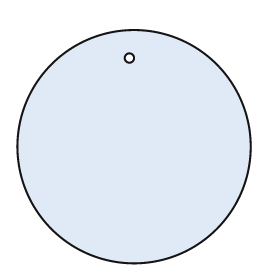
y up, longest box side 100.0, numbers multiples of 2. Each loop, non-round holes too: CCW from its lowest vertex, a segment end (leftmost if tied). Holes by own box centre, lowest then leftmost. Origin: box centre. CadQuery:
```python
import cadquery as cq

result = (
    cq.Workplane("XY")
    .moveTo(0.0, 0.0)
    .circle(50.0)
    .moveTo(-2.0, 38.0)
    .circle(2.0)
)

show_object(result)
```